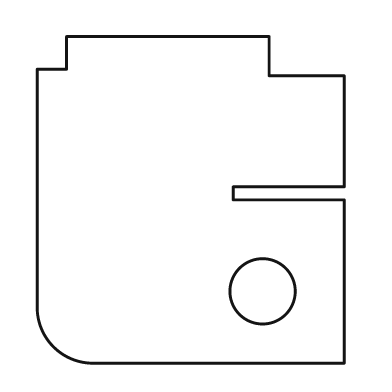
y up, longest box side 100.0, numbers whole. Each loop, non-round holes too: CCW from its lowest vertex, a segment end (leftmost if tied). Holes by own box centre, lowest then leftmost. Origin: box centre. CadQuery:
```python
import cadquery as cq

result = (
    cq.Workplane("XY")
    .moveTo(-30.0, -50.0)
    .lineTo(47.0, -50.0)
    .lineTo(47.0, 0.0)
    .lineTo(13.0, 0.0)
    .lineTo(13.0, 4.0)
    .lineTo(47.0, 4.0)
    .lineTo(47.0, 38.0)
    .lineTo(24.0, 38.0)
    .lineTo(24.0, 50.0)
    .lineTo(-38.0, 50.0)
    .lineTo(-38.0, 40.0)
    .lineTo(-47.0, 40.0)
    .lineTo(-47.0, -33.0)
    .threePointArc((-42.0, -45.0), (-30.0, -50.0))
    .close()
    .moveTo(22.0, -28.0)
    .circle(10.0)
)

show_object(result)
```